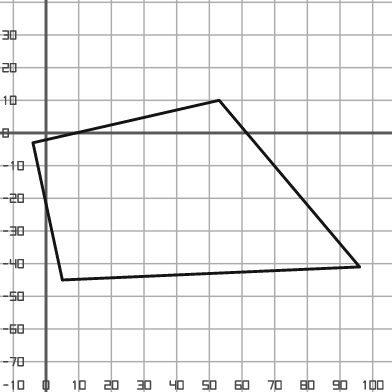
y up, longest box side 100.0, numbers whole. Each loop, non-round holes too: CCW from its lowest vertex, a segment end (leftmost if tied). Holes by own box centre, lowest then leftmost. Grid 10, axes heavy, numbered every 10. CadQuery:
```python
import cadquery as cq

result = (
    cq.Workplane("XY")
    .moveTo(5.0, -45.0)
    .lineTo(96.0, -41.0)
    .lineTo(53.0, 10.0)
    .lineTo(-4.0, -3.0)
    .close()
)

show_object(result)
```